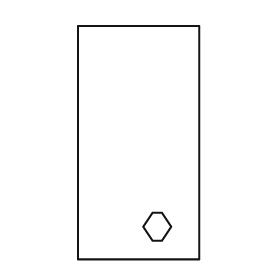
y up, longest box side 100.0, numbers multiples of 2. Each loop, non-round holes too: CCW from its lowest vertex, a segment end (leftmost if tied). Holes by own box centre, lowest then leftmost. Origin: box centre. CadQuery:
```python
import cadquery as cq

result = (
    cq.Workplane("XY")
    .moveTo(-26.0, -50.0)
    .lineTo(26.0, -50.0)
    .lineTo(26.0, 50.0)
    .lineTo(-26.0, 50.0)
    .close()
    .moveTo(6.0, -42.0)
    .lineTo(10.0, -42.0)
    .lineTo(14.0, -36.0)
    .lineTo(10.0, -30.0)
    .lineTo(6.0, -30.0)
    .lineTo(2.0, -36.0)
    .close()
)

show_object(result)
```